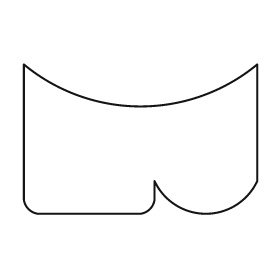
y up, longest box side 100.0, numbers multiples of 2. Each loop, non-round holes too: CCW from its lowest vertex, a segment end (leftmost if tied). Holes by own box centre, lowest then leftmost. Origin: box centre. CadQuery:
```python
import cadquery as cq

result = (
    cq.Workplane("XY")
    .moveTo(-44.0, -32.0)
    .lineTo(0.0, -32.0)
    .threePointArc((4.0, -30.0), (6.0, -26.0))
    .lineTo(6.0, -18.0)
    .threePointArc((28.0, -32.0), (50.0, -18.0))
    .lineTo(50.0, 32.0)
    .threePointArc((0.0, 14.0), (-50.0, 32.0))
    .lineTo(-50.0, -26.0)
    .threePointArc((-48.0, -30.0), (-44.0, -32.0))
    .close()
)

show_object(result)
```